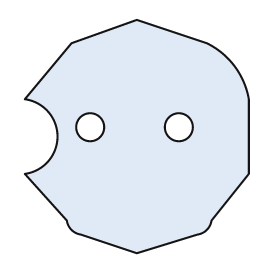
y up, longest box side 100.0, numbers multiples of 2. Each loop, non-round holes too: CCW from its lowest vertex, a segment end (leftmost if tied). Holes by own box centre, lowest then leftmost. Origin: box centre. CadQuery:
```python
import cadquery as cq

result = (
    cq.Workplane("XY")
    .moveTo(0.0, -50.0)
    .lineTo(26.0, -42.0)
    .threePointArc((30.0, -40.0), (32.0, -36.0))
    .lineTo(48.0, -16.0)
    .lineTo(48.0, 16.0)
    .threePointArc((42.0, 30.0), (30.0, 40.0))
    .lineTo(0.0, 50.0)
    .lineTo(-28.0, 40.0)
    .lineTo(-48.0, 16.0)
    .threePointArc((-34.0, 0.0), (-48.0, -16.0))
    .lineTo(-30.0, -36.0)
    .threePointArc((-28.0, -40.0), (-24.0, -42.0))
    .close()
    .moveTo(-20.0, 4.0)
    .circle(6.0)
    .moveTo(18.0, 4.0)
    .circle(6.0)
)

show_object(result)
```